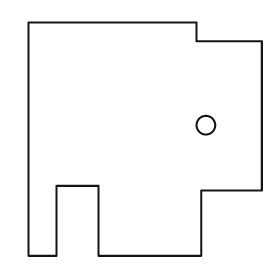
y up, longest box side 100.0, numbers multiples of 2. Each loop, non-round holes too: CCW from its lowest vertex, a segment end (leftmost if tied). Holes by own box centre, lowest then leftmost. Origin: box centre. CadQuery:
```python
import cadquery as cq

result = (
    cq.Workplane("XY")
    .moveTo(-50.0, -50.0)
    .lineTo(-38.0, -50.0)
    .lineTo(-38.0, -20.0)
    .lineTo(-20.0, -20.0)
    .lineTo(-20.0, -50.0)
    .lineTo(24.0, -50.0)
    .lineTo(24.0, -22.0)
    .lineTo(50.0, -22.0)
    .lineTo(50.0, 42.0)
    .lineTo(22.0, 42.0)
    .lineTo(22.0, 50.0)
    .lineTo(-50.0, 50.0)
    .close()
    .moveTo(26.0, 6.0)
    .circle(4.0)
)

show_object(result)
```